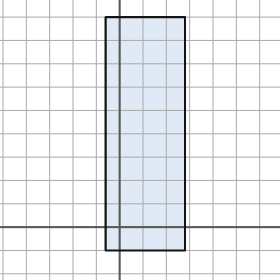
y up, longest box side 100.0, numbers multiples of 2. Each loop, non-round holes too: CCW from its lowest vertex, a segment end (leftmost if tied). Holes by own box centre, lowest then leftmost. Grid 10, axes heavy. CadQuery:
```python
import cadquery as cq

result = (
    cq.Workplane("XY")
    .moveTo(-6.0, -10.0)
    .lineTo(28.0, -10.0)
    .lineTo(28.0, 90.0)
    .lineTo(-6.0, 90.0)
    .close()
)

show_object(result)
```